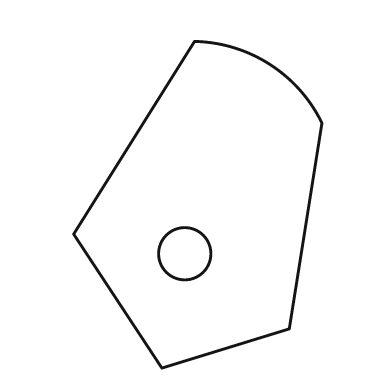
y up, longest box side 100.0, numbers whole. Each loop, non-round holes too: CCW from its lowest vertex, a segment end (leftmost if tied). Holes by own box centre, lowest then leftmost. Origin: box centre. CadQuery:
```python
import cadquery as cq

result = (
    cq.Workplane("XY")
    .moveTo(-11.0, -50.0)
    .lineTo(28.0, -38.0)
    .lineTo(38.0, 25.0)
    .threePointArc((22.0, 43.0), (-1.0, 50.0))
    .lineTo(-38.0, -9.0)
    .close()
    .moveTo(-4.0, -15.0)
    .circle(8.0)
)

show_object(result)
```